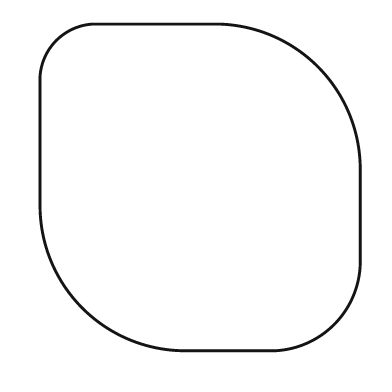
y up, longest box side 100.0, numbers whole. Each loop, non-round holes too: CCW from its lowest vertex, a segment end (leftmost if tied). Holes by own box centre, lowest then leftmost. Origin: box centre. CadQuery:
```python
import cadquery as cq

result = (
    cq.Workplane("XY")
    .moveTo(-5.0, -50.0)
    .lineTo(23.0, -50.0)
    .threePointArc((41.0, -42.0), (49.0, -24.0))
    .lineTo(49.0, 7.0)
    .threePointArc((36.0, 37.0), (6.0, 50.0))
    .lineTo(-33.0, 50.0)
    .threePointArc((-44.0, 45.0), (-49.0, 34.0))
    .lineTo(-49.0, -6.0)
    .threePointArc((-36.0, -37.0), (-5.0, -50.0))
    .close()
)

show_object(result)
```